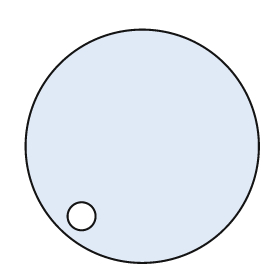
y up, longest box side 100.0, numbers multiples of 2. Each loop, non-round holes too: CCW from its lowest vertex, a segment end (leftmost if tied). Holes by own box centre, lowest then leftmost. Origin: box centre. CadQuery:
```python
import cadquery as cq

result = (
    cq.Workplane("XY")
    .moveTo(0.0, 0.0)
    .circle(50.0)
    .moveTo(-26.0, -30.0)
    .circle(6.0)
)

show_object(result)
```